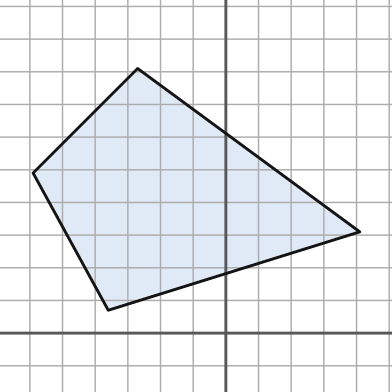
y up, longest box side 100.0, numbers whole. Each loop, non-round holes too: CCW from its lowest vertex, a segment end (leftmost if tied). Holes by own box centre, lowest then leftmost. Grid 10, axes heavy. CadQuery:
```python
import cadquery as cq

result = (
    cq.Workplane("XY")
    .moveTo(-36.0, 7.0)
    .lineTo(41.0, 31.0)
    .lineTo(-27.0, 81.0)
    .lineTo(-59.0, 49.0)
    .close()
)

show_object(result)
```